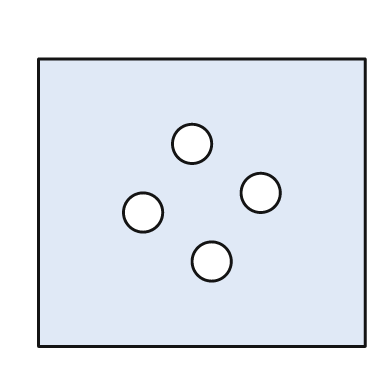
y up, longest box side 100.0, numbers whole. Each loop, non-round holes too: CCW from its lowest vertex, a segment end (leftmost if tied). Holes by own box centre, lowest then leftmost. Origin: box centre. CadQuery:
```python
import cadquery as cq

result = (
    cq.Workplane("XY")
    .moveTo(-50.0, -44.0)
    .lineTo(50.0, -44.0)
    .lineTo(50.0, 44.0)
    .lineTo(-50.0, 44.0)
    .close()
    .moveTo(3.0, -18.0)
    .circle(6.0)
    .moveTo(-18.0, -3.0)
    .circle(6.0)
    .moveTo(18.0, 3.0)
    .circle(6.0)
    .moveTo(-3.0, 18.0)
    .circle(6.0)
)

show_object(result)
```